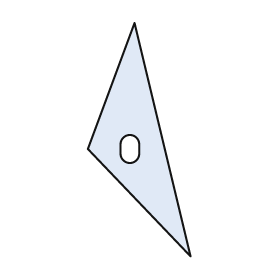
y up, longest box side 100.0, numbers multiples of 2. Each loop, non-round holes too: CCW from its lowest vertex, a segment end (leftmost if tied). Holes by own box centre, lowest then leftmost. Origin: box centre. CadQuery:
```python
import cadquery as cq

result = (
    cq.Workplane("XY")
    .moveTo(22.0, -50.0)
    .lineTo(-2.0, 50.0)
    .lineTo(-22.0, -4.0)
    .close()
    .moveTo(-8.0, -6.0)
    .threePointArc((-4.0, -10.0), (0.0, -6.0))
    .lineTo(0.0, -2.0)
    .threePointArc((-4.0, 2.0), (-8.0, -2.0))
    .close()
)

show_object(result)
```